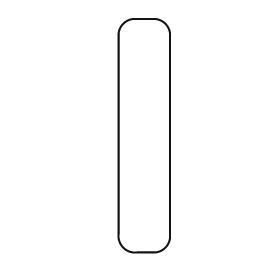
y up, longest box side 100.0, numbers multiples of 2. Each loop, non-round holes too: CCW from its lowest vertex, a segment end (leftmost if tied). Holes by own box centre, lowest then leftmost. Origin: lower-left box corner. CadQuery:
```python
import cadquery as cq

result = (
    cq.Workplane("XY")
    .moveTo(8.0, 0.0)
    .lineTo(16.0, 0.0)
    .threePointArc((20.0, 2.0), (22.0, 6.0))
    .lineTo(22.0, 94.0)
    .threePointArc((20.0, 98.0), (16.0, 100.0))
    .lineTo(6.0, 100.0)
    .threePointArc((2.0, 98.0), (0.0, 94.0))
    .lineTo(0.0, 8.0)
    .threePointArc((2.0, 2.0), (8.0, 0.0))
    .close()
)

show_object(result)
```